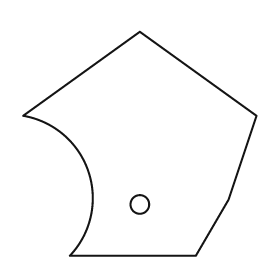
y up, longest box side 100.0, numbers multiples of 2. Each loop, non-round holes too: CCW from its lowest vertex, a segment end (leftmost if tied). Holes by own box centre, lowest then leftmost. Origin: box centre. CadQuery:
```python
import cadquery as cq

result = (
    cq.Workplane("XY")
    .moveTo(-30.0, -48.0)
    .lineTo(24.0, -48.0)
    .lineTo(38.0, -24.0)
    .lineTo(50.0, 12.0)
    .lineTo(0.0, 48.0)
    .lineTo(-50.0, 12.0)
    .threePointArc((-22.0, -12.0), (-30.0, -48.0))
    .close()
    .moveTo(0.0, -26.0)
    .circle(4.0)
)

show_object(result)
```